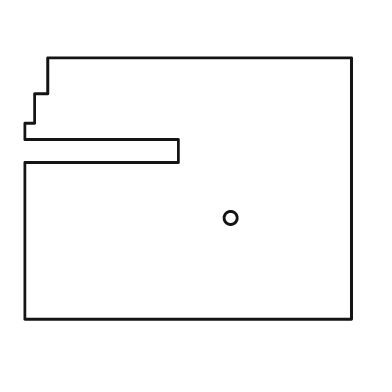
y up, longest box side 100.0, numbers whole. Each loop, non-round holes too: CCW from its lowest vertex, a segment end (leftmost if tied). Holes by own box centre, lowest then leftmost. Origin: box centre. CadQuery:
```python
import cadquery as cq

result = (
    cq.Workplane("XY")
    .moveTo(-50.0, -40.0)
    .lineTo(50.0, -40.0)
    .lineTo(50.0, 40.0)
    .lineTo(-43.0, 40.0)
    .lineTo(-43.0, 29.0)
    .lineTo(-47.0, 29.0)
    .lineTo(-47.0, 20.0)
    .lineTo(-50.0, 20.0)
    .lineTo(-50.0, 15.0)
    .lineTo(-3.0, 15.0)
    .lineTo(-3.0, 8.0)
    .lineTo(-50.0, 8.0)
    .close()
    .moveTo(13.0, -9.0)
    .circle(2.0)
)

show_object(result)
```